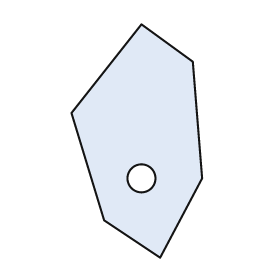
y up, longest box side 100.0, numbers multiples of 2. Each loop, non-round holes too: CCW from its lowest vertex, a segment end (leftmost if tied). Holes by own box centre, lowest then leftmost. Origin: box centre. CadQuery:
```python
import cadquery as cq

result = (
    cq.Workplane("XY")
    .moveTo(10.0, -50.0)
    .lineTo(28.0, -16.0)
    .lineTo(24.0, 34.0)
    .lineTo(2.0, 50.0)
    .lineTo(-28.0, 12.0)
    .lineTo(-14.0, -34.0)
    .close()
    .moveTo(2.0, -16.0)
    .circle(6.0)
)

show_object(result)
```